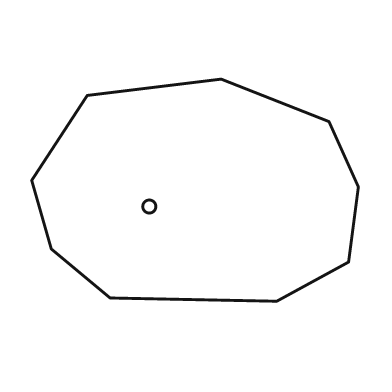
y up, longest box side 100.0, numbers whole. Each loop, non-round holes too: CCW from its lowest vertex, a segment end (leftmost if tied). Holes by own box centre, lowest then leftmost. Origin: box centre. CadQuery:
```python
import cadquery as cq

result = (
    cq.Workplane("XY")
    .moveTo(25.0, -34.0)
    .lineTo(47.0, -22.0)
    .lineTo(50.0, 1.0)
    .lineTo(41.0, 21.0)
    .lineTo(8.0, 34.0)
    .lineTo(-33.0, 29.0)
    .lineTo(-50.0, 3.0)
    .lineTo(-44.0, -18.0)
    .lineTo(-26.0, -33.0)
    .close()
    .moveTo(-14.0, -5.0)
    .circle(2.0)
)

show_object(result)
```